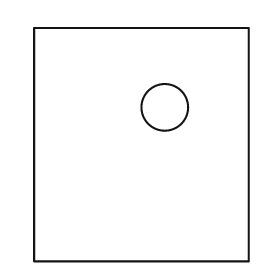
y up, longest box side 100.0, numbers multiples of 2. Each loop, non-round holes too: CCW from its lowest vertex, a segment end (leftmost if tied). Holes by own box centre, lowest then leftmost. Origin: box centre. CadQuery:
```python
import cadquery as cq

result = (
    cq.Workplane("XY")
    .moveTo(-46.0, -50.0)
    .lineTo(46.0, -50.0)
    .lineTo(46.0, 50.0)
    .lineTo(-46.0, 50.0)
    .close()
    .moveTo(10.0, 16.0)
    .circle(10.0)
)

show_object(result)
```